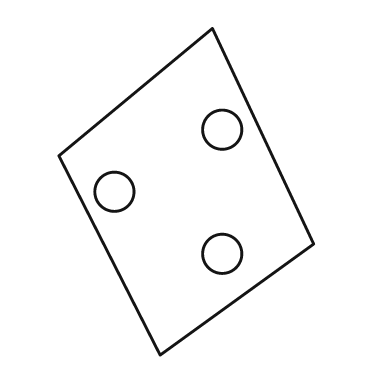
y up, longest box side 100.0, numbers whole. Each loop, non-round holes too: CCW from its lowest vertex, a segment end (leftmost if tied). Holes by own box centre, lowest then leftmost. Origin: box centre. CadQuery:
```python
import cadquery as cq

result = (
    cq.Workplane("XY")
    .moveTo(-8.0, -50.0)
    .lineTo(39.0, -16.0)
    .lineTo(8.0, 50.0)
    .lineTo(-39.0, 11.0)
    .close()
    .moveTo(11.0, -19.0)
    .circle(6.0)
    .moveTo(-22.0, 0.0)
    .circle(6.0)
    .moveTo(11.0, 19.0)
    .circle(6.0)
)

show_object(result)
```